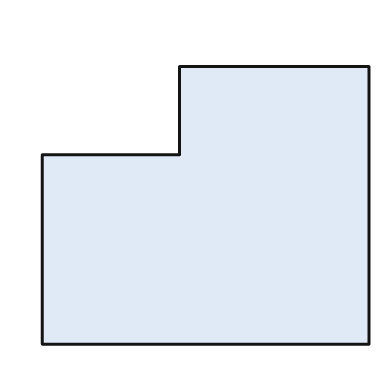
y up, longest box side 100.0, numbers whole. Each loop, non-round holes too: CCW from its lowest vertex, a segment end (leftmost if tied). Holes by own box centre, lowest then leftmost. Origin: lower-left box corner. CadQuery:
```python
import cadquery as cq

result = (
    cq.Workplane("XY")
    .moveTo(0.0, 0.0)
    .lineTo(100.0, 0.0)
    .lineTo(100.0, 85.0)
    .lineTo(42.0, 85.0)
    .lineTo(42.0, 58.0)
    .lineTo(0.0, 58.0)
    .close()
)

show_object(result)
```